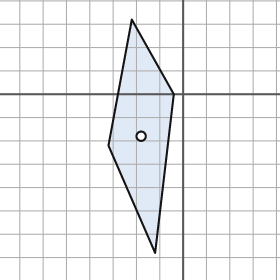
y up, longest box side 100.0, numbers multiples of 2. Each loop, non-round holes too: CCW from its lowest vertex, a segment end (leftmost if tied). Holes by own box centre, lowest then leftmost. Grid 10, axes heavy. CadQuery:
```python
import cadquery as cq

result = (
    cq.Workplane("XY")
    .moveTo(-12.0, -68.0)
    .lineTo(-4.0, 0.0)
    .lineTo(-22.0, 32.0)
    .lineTo(-32.0, -22.0)
    .close()
    .moveTo(-18.0, -18.0)
    .circle(2.0)
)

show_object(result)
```